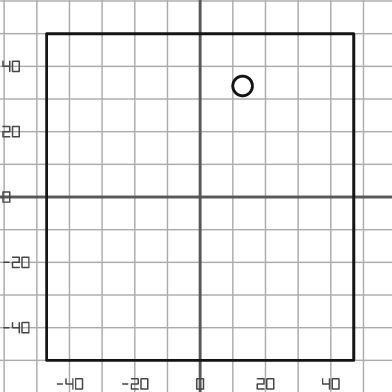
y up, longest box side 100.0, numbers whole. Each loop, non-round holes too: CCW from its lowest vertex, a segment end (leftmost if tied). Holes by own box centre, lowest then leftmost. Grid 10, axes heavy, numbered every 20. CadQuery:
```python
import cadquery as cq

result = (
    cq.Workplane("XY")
    .moveTo(-47.0, -50.0)
    .lineTo(47.0, -50.0)
    .lineTo(47.0, 50.0)
    .lineTo(-47.0, 50.0)
    .close()
    .moveTo(13.0, 34.0)
    .circle(3.0)
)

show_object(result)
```